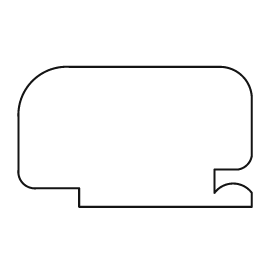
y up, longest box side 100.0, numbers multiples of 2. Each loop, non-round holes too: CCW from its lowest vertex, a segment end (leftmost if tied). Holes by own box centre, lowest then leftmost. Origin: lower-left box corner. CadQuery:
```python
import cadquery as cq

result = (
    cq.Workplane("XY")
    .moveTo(26.0, 0.0)
    .lineTo(100.0, 0.0)
    .lineTo(100.0, 6.0)
    .threePointArc((92.0, 10.0), (84.0, 6.0))
    .lineTo(84.0, 16.0)
    .lineTo(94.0, 16.0)
    .threePointArc((98.0, 18.0), (100.0, 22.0))
    .lineTo(100.0, 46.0)
    .threePointArc((96.0, 56.0), (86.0, 60.0))
    .lineTo(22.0, 60.0)
    .threePointArc((6.0, 54.0), (0.0, 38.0))
    .lineTo(0.0, 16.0)
    .threePointArc((2.0, 10.0), (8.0, 8.0))
    .lineTo(26.0, 8.0)
    .close()
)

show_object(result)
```